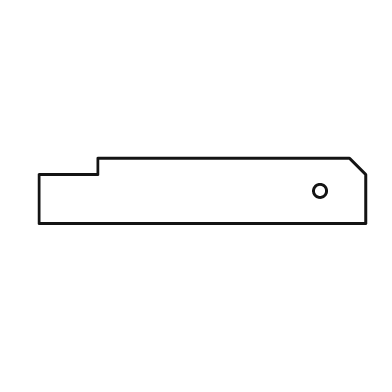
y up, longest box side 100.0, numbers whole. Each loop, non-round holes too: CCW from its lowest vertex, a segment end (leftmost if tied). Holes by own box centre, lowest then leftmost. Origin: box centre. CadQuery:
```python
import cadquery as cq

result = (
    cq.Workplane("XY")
    .moveTo(-50.0, -10.0)
    .lineTo(50.0, -10.0)
    .lineTo(50.0, 5.0)
    .lineTo(45.0, 10.0)
    .lineTo(-32.0, 10.0)
    .lineTo(-32.0, 5.0)
    .lineTo(-50.0, 5.0)
    .close()
    .moveTo(36.0, 0.0)
    .circle(2.0)
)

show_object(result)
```